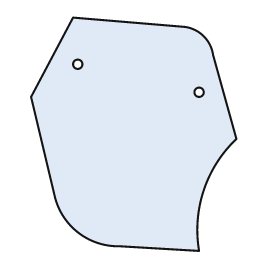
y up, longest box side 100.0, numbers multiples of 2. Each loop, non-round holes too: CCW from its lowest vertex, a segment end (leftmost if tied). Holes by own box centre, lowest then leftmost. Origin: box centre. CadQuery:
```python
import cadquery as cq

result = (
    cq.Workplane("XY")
    .moveTo(28.0, -50.0)
    .threePointArc((30.0, -24.0), (44.0, -2.0))
    .lineTo(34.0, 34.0)
    .threePointArc((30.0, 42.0), (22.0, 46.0))
    .lineTo(-26.0, 50.0)
    .lineTo(-44.0, 16.0)
    .lineTo(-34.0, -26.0)
    .threePointArc((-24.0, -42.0), (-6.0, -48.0))
    .close()
    .moveTo(28.0, 18.0)
    .circle(2.0)
    .moveTo(-24.0, 30.0)
    .circle(2.0)
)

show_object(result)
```